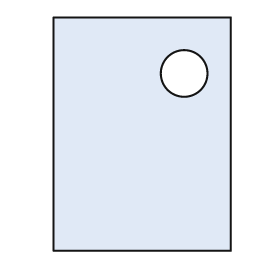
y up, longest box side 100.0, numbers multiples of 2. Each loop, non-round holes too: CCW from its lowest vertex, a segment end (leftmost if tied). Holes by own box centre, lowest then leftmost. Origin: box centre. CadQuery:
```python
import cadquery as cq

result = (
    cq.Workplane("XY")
    .moveTo(-38.0, -50.0)
    .lineTo(38.0, -50.0)
    .lineTo(38.0, 50.0)
    .lineTo(-38.0, 50.0)
    .close()
    .moveTo(18.0, 26.0)
    .circle(10.0)
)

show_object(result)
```